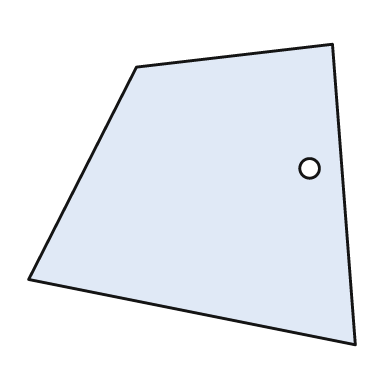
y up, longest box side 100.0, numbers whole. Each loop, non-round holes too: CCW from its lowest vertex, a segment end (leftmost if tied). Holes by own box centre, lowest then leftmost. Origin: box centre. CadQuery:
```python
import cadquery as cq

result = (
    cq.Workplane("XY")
    .moveTo(50.0, -46.0)
    .lineTo(43.0, 46.0)
    .lineTo(-17.0, 39.0)
    .lineTo(-50.0, -26.0)
    .close()
    .moveTo(36.0, 8.0)
    .circle(3.0)
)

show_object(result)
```